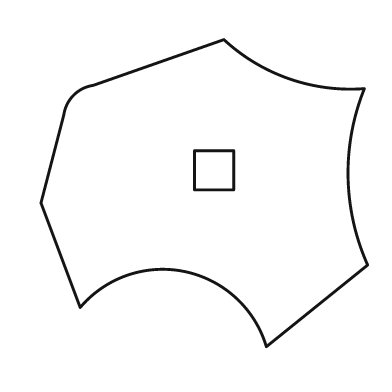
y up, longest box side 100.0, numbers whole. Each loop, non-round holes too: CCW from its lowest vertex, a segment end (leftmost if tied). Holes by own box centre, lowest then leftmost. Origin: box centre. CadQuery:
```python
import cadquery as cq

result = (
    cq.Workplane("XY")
    .moveTo(19.0, -47.0)
    .lineTo(50.0, -22.0)
    .threePointArc((44.0, 5.0), (49.0, 32.0))
    .threePointArc((26.0, 35.0), (6.0, 47.0))
    .lineTo(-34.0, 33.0)
    .threePointArc((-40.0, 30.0), (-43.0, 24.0))
    .lineTo(-50.0, -3.0)
    .lineTo(-38.0, -35.0)
    .threePointArc((-6.0, -24.0), (19.0, -47.0))
    .close()
    .moveTo(-3.0, 1.0)
    .lineTo(9.0, 1.0)
    .lineTo(9.0, 13.0)
    .lineTo(-3.0, 13.0)
    .close()
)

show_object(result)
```